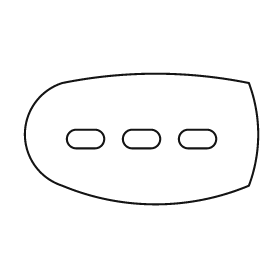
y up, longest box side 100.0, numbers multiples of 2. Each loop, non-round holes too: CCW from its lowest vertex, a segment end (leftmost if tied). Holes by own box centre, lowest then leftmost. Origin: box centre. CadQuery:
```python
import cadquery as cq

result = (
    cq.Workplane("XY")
    .moveTo(-34.0, -20.0)
    .threePointArc((6.0, -28.0), (46.0, -20.0))
    .threePointArc((50.0, 2.0), (46.0, 24.0))
    .threePointArc((6.0, 28.0), (-34.0, 24.0))
    .threePointArc((-50.0, 2.0), (-34.0, -20.0))
    .close()
    .moveTo(-28.0, -4.0)
    .lineTo(-20.0, -4.0)
    .threePointArc((-16.0, 0.0), (-20.0, 4.0))
    .lineTo(-28.0, 4.0)
    .threePointArc((-32.0, 0.0), (-28.0, -4.0))
    .close()
    .moveTo(-4.0, -4.0)
    .lineTo(4.0, -4.0)
    .threePointArc((8.0, 0.0), (4.0, 4.0))
    .lineTo(-4.0, 4.0)
    .threePointArc((-8.0, 0.0), (-4.0, -4.0))
    .close()
    .moveTo(20.0, -4.0)
    .lineTo(28.0, -4.0)
    .threePointArc((32.0, 0.0), (28.0, 4.0))
    .lineTo(20.0, 4.0)
    .threePointArc((16.0, 0.0), (20.0, -4.0))
    .close()
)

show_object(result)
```